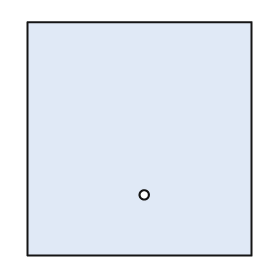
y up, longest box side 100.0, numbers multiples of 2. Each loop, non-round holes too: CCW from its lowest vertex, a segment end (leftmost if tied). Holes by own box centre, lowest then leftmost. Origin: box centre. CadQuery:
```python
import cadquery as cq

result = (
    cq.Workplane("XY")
    .moveTo(-48.0, -50.0)
    .lineTo(48.0, -50.0)
    .lineTo(48.0, 50.0)
    .lineTo(-48.0, 50.0)
    .close()
    .moveTo(2.0, -24.0)
    .circle(2.0)
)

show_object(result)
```